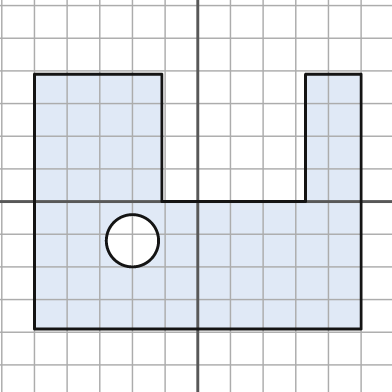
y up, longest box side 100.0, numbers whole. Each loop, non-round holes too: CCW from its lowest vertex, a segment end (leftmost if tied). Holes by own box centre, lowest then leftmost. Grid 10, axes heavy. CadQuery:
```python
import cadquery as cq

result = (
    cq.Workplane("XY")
    .moveTo(-50.0, -39.0)
    .lineTo(50.0, -39.0)
    .lineTo(50.0, 39.0)
    .lineTo(33.0, 39.0)
    .lineTo(33.0, 0.0)
    .lineTo(-11.0, 0.0)
    .lineTo(-11.0, 39.0)
    .lineTo(-50.0, 39.0)
    .close()
    .moveTo(-20.0, -12.0)
    .circle(8.0)
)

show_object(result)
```